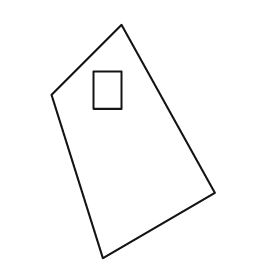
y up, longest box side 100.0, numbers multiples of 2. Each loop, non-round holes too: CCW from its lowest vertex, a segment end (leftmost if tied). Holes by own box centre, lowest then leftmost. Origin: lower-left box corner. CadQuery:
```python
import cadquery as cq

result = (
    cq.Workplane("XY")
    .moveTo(22.0, 0.0)
    .lineTo(70.0, 28.0)
    .lineTo(30.0, 100.0)
    .lineTo(0.0, 70.0)
    .close()
    .moveTo(18.0, 64.0)
    .lineTo(30.0, 64.0)
    .lineTo(30.0, 80.0)
    .lineTo(18.0, 80.0)
    .close()
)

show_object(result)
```